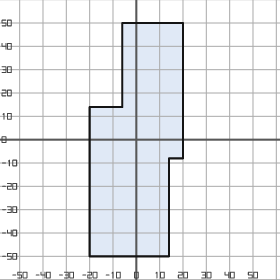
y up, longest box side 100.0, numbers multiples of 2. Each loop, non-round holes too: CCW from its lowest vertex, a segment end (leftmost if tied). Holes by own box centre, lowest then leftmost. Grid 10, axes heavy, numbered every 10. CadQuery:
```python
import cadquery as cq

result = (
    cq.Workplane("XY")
    .moveTo(-20.0, -50.0)
    .lineTo(14.0, -50.0)
    .lineTo(14.0, -8.0)
    .lineTo(20.0, -8.0)
    .lineTo(20.0, 50.0)
    .lineTo(-6.0, 50.0)
    .lineTo(-6.0, 14.0)
    .lineTo(-20.0, 14.0)
    .close()
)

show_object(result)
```